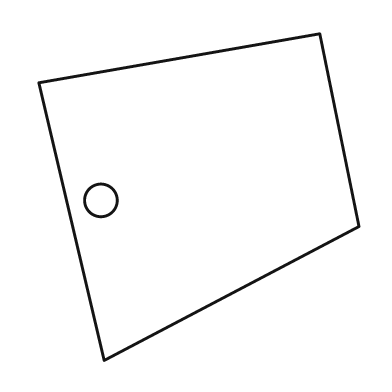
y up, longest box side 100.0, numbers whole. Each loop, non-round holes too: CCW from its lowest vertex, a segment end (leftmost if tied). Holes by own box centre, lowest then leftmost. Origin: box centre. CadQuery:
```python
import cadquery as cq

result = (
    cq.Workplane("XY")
    .moveTo(-29.0, -50.0)
    .lineTo(49.0, -9.0)
    .lineTo(37.0, 50.0)
    .lineTo(-49.0, 35.0)
    .close()
    .moveTo(-30.0, -1.0)
    .circle(5.0)
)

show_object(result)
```